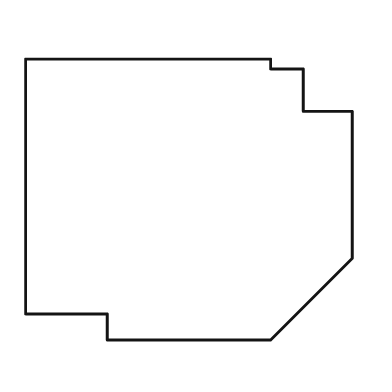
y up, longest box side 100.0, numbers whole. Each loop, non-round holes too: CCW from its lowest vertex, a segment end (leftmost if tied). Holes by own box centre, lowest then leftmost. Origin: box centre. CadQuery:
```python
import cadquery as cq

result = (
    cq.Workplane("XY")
    .moveTo(-25.0, -43.0)
    .lineTo(25.0, -43.0)
    .lineTo(50.0, -18.0)
    .lineTo(50.0, 27.0)
    .lineTo(35.0, 27.0)
    .lineTo(35.0, 40.0)
    .lineTo(25.0, 40.0)
    .lineTo(25.0, 43.0)
    .lineTo(-50.0, 43.0)
    .lineTo(-50.0, -35.0)
    .lineTo(-25.0, -35.0)
    .close()
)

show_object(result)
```